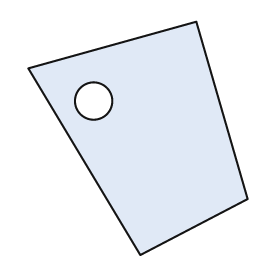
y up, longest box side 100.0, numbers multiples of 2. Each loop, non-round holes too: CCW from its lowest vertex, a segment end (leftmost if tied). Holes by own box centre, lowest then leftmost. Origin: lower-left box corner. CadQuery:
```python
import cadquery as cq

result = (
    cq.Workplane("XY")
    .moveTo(48.0, 0.0)
    .lineTo(94.0, 24.0)
    .lineTo(72.0, 100.0)
    .lineTo(0.0, 80.0)
    .close()
    .moveTo(28.0, 66.0)
    .circle(8.0)
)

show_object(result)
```